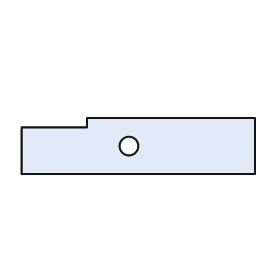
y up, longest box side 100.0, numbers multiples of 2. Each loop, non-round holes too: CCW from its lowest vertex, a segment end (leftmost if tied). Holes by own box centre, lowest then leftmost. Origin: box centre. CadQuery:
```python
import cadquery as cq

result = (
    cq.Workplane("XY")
    .moveTo(-50.0, -12.0)
    .lineTo(50.0, -12.0)
    .lineTo(50.0, 12.0)
    .lineTo(-22.0, 12.0)
    .lineTo(-22.0, 8.0)
    .lineTo(-50.0, 8.0)
    .close()
    .moveTo(-4.0, 0.0)
    .circle(4.0)
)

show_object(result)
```